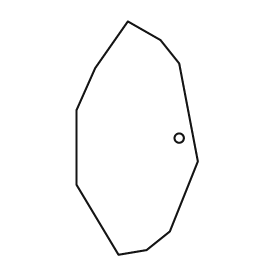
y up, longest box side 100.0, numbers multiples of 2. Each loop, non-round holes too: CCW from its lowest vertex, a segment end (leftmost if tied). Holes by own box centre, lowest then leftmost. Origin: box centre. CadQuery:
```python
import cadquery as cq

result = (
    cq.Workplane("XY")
    .moveTo(-8.0, -50.0)
    .lineTo(4.0, -48.0)
    .lineTo(14.0, -40.0)
    .lineTo(26.0, -10.0)
    .lineTo(18.0, 32.0)
    .lineTo(10.0, 42.0)
    .lineTo(-4.0, 50.0)
    .lineTo(-18.0, 30.0)
    .lineTo(-26.0, 12.0)
    .lineTo(-26.0, -20.0)
    .close()
    .moveTo(18.0, 0.0)
    .circle(2.0)
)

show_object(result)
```